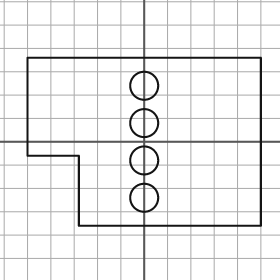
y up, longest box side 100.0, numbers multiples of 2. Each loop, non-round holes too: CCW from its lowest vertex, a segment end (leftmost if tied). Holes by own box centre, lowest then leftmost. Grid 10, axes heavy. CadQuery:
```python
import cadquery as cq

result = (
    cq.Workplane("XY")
    .moveTo(-28.0, -36.0)
    .lineTo(50.0, -36.0)
    .lineTo(50.0, 36.0)
    .lineTo(-50.0, 36.0)
    .lineTo(-50.0, -6.0)
    .lineTo(-28.0, -6.0)
    .close()
    .moveTo(0.0, -24.0)
    .circle(6.0)
    .moveTo(0.0, -8.0)
    .circle(6.0)
    .moveTo(0.0, 8.0)
    .circle(6.0)
    .moveTo(0.0, 24.0)
    .circle(6.0)
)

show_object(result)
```